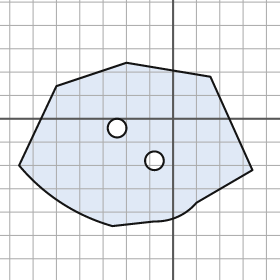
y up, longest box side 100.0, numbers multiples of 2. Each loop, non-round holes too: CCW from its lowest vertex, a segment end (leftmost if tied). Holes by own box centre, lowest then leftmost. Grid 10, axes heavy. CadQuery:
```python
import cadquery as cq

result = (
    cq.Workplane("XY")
    .moveTo(-26.0, -46.0)
    .lineTo(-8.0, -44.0)
    .threePointArc((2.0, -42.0), (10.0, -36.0))
    .lineTo(34.0, -22.0)
    .lineTo(16.0, 18.0)
    .lineTo(-20.0, 24.0)
    .lineTo(-50.0, 14.0)
    .lineTo(-66.0, -20.0)
    .threePointArc((-48.0, -36.0), (-26.0, -46.0))
    .close()
    .moveTo(-8.0, -18.0)
    .circle(4.0)
    .moveTo(-24.0, -4.0)
    .circle(4.0)
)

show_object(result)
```